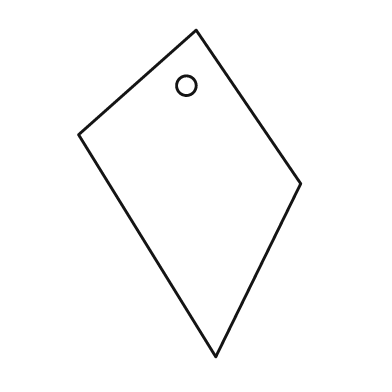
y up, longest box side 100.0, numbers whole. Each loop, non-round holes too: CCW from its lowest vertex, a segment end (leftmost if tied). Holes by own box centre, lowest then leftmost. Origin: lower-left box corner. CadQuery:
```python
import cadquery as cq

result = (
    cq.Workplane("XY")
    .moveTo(42.0, 0.0)
    .lineTo(68.0, 53.0)
    .lineTo(36.0, 100.0)
    .lineTo(0.0, 68.0)
    .close()
    .moveTo(33.0, 83.0)
    .circle(3.0)
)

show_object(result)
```